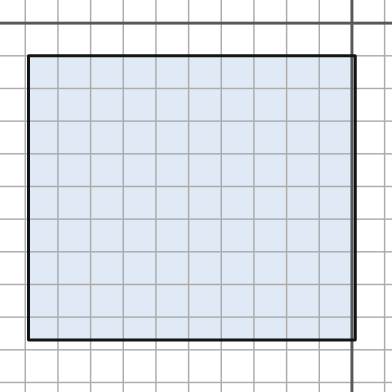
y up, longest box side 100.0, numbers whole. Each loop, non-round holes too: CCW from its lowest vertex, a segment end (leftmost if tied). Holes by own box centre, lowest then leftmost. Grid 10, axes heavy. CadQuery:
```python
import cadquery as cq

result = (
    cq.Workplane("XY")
    .moveTo(-99.0, -97.0)
    .lineTo(1.0, -97.0)
    .lineTo(1.0, -10.0)
    .lineTo(-99.0, -10.0)
    .close()
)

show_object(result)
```